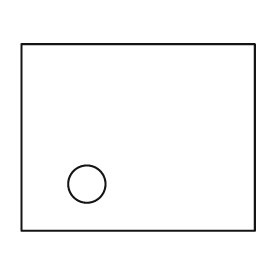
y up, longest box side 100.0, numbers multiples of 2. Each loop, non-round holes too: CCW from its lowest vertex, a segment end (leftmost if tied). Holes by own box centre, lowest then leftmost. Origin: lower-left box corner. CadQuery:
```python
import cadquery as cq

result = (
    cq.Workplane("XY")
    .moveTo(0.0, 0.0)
    .lineTo(100.0, 0.0)
    .lineTo(100.0, 80.0)
    .lineTo(0.0, 80.0)
    .close()
    .moveTo(28.0, 20.0)
    .circle(8.0)
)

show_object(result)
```